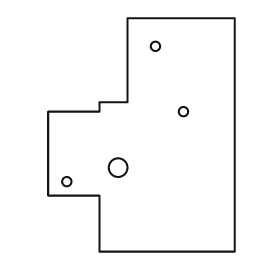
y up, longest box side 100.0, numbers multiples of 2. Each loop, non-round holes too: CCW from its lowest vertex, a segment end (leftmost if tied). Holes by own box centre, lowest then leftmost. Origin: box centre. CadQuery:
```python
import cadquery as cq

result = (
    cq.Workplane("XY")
    .moveTo(-18.0, -50.0)
    .lineTo(40.0, -50.0)
    .lineTo(40.0, 50.0)
    .lineTo(-6.0, 50.0)
    .lineTo(-6.0, 14.0)
    .lineTo(-18.0, 14.0)
    .lineTo(-18.0, 10.0)
    .lineTo(-40.0, 10.0)
    .lineTo(-40.0, -26.0)
    .lineTo(-18.0, -26.0)
    .close()
    .moveTo(-32.0, -20.0)
    .circle(2.0)
    .moveTo(-10.0, -14.0)
    .circle(4.0)
    .moveTo(18.0, 10.0)
    .circle(2.0)
    .moveTo(6.0, 38.0)
    .circle(2.0)
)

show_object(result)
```